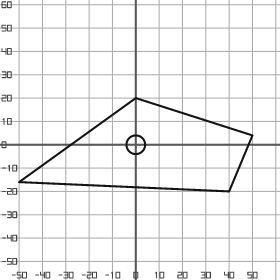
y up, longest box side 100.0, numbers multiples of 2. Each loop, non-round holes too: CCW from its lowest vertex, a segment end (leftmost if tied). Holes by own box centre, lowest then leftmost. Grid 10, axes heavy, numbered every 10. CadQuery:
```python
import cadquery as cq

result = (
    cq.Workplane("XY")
    .moveTo(40.0, -20.0)
    .lineTo(50.0, 4.0)
    .lineTo(0.0, 20.0)
    .lineTo(-50.0, -16.0)
    .close()
    .moveTo(0.0, 0.0)
    .circle(4.0)
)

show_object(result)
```